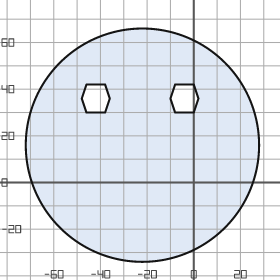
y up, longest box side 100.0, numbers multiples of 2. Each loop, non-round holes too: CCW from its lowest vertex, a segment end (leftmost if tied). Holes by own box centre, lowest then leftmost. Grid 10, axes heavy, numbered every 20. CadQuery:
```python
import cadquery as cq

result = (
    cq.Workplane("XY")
    .moveTo(-22.0, 16.0)
    .circle(50.0)
    .moveTo(-46.0, 30.0)
    .lineTo(-38.0, 30.0)
    .lineTo(-36.0, 36.0)
    .lineTo(-38.0, 42.0)
    .lineTo(-46.0, 42.0)
    .lineTo(-48.0, 36.0)
    .close()
    .moveTo(-8.0, 30.0)
    .lineTo(0.0, 30.0)
    .lineTo(2.0, 36.0)
    .lineTo(0.0, 42.0)
    .lineTo(-8.0, 42.0)
    .lineTo(-10.0, 36.0)
    .close()
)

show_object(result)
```